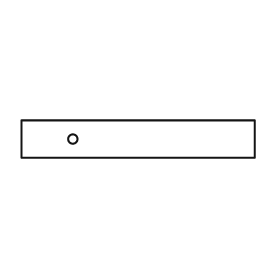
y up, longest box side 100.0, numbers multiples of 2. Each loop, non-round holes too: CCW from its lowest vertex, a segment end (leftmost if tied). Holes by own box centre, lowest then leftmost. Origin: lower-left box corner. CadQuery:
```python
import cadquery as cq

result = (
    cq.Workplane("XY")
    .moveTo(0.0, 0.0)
    .lineTo(100.0, 0.0)
    .lineTo(100.0, 16.0)
    .lineTo(0.0, 16.0)
    .close()
    .moveTo(22.0, 8.0)
    .circle(2.0)
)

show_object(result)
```